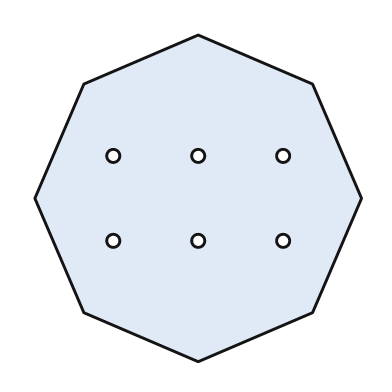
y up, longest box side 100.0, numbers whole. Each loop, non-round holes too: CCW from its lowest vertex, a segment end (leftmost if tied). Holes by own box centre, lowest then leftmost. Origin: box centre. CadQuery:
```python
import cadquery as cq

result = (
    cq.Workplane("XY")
    .moveTo(0.0, -50.0)
    .lineTo(35.0, -35.0)
    .lineTo(50.0, 0.0)
    .lineTo(35.0, 35.0)
    .lineTo(0.0, 50.0)
    .lineTo(-35.0, 35.0)
    .lineTo(-50.0, 0.0)
    .lineTo(-35.0, -35.0)
    .close()
    .moveTo(-26.0, -13.0)
    .circle(2.0)
    .moveTo(0.0, -13.0)
    .circle(2.0)
    .moveTo(26.0, -13.0)
    .circle(2.0)
    .moveTo(-26.0, 13.0)
    .circle(2.0)
    .moveTo(0.0, 13.0)
    .circle(2.0)
    .moveTo(26.0, 13.0)
    .circle(2.0)
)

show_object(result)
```